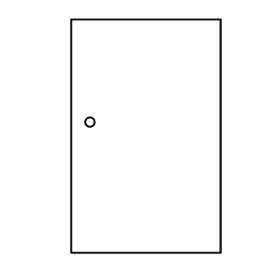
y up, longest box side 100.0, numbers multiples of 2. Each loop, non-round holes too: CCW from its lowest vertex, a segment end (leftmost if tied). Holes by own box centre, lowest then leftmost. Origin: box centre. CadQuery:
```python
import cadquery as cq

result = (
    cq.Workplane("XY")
    .moveTo(-32.0, -50.0)
    .lineTo(32.0, -50.0)
    .lineTo(32.0, 50.0)
    .lineTo(-32.0, 50.0)
    .close()
    .moveTo(-24.0, 6.0)
    .circle(2.0)
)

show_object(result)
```